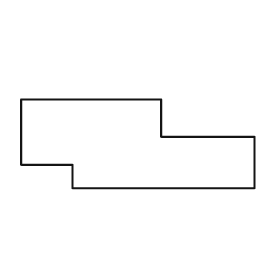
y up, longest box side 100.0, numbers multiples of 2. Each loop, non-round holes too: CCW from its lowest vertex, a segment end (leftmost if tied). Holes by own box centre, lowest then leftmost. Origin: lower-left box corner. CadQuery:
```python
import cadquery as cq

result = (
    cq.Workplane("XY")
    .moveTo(22.0, 0.0)
    .lineTo(100.0, 0.0)
    .lineTo(100.0, 22.0)
    .lineTo(60.0, 22.0)
    .lineTo(60.0, 38.0)
    .lineTo(0.0, 38.0)
    .lineTo(0.0, 10.0)
    .lineTo(22.0, 10.0)
    .close()
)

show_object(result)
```